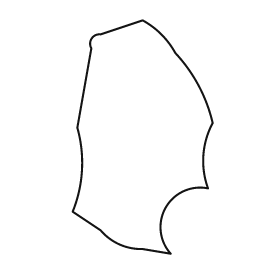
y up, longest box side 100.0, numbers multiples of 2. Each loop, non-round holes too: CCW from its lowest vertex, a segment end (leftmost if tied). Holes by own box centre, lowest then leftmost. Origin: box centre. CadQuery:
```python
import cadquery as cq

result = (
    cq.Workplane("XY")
    .moveTo(12.0, -50.0)
    .threePointArc((10.0, -30.0), (28.0, -22.0))
    .threePointArc((26.0, -8.0), (30.0, 6.0))
    .threePointArc((24.0, 22.0), (14.0, 36.0))
    .threePointArc((8.0, 44.0), (0.0, 50.0))
    .lineTo(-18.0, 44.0)
    .threePointArc((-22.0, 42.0), (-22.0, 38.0))
    .lineTo(-28.0, 4.0)
    .threePointArc((-26.0, -14.0), (-30.0, -32.0))
    .lineTo(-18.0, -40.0)
    .threePointArc((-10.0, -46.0), (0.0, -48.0))
    .close()
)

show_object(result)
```